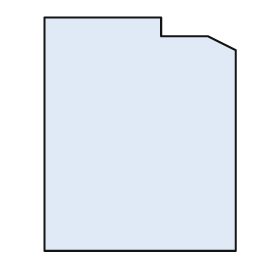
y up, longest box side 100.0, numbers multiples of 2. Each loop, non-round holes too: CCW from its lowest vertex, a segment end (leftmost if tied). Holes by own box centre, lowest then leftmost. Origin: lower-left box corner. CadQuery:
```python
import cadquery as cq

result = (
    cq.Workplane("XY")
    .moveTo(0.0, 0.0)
    .lineTo(82.0, 0.0)
    .lineTo(82.0, 86.0)
    .lineTo(70.0, 92.0)
    .lineTo(50.0, 92.0)
    .lineTo(50.0, 100.0)
    .lineTo(0.0, 100.0)
    .close()
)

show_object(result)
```